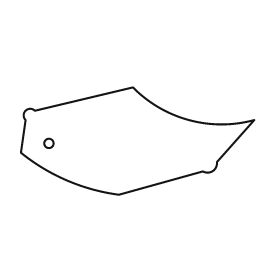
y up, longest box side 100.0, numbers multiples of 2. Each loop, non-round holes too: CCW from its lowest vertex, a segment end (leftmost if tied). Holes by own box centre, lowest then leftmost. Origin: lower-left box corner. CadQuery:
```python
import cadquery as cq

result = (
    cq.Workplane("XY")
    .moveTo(42.0, 0.0)
    .lineTo(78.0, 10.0)
    .threePointArc((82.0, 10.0), (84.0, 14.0))
    .lineTo(100.0, 32.0)
    .threePointArc((72.0, 32.0), (48.0, 46.0))
    .lineTo(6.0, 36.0)
    .threePointArc((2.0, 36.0), (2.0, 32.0))
    .lineTo(0.0, 18.0)
    .threePointArc((20.0, 6.0), (42.0, 0.0))
    .close()
    .moveTo(12.0, 22.0)
    .circle(2.0)
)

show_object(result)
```